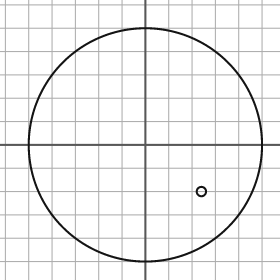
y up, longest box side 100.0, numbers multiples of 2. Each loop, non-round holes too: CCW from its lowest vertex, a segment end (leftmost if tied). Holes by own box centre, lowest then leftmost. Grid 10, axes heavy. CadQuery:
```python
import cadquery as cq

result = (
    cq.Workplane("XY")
    .moveTo(0.0, 0.0)
    .circle(50.0)
    .moveTo(24.0, -20.0)
    .circle(2.0)
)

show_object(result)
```